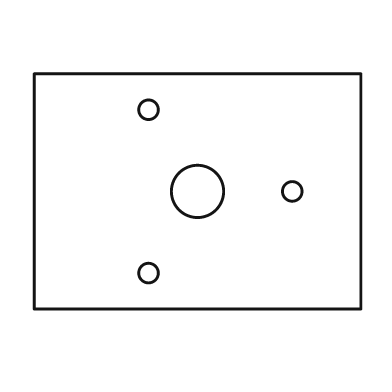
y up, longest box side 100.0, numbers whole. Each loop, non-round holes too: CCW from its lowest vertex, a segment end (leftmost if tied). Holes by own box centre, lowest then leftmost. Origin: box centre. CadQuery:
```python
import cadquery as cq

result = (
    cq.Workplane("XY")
    .moveTo(-50.0, -36.0)
    .lineTo(50.0, -36.0)
    .lineTo(50.0, 36.0)
    .lineTo(-50.0, 36.0)
    .close()
    .moveTo(-15.0, -25.0)
    .circle(3.0)
    .moveTo(0.0, 0.0)
    .circle(8.0)
    .moveTo(29.0, 0.0)
    .circle(3.0)
    .moveTo(-15.0, 25.0)
    .circle(3.0)
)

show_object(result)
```